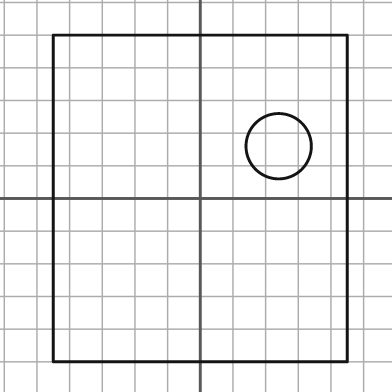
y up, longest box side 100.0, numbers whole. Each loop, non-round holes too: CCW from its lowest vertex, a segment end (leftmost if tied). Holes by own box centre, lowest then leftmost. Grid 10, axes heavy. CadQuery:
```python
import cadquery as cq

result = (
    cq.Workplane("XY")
    .moveTo(-45.0, -50.0)
    .lineTo(45.0, -50.0)
    .lineTo(45.0, 50.0)
    .lineTo(-45.0, 50.0)
    .close()
    .moveTo(24.0, 16.0)
    .circle(10.0)
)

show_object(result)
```